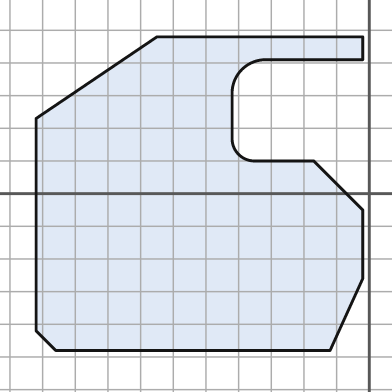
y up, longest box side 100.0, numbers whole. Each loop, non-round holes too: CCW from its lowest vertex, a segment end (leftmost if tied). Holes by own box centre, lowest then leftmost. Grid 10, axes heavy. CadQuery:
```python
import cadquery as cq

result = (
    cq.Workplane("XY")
    .moveTo(-96.0, -48.0)
    .lineTo(-12.0, -48.0)
    .lineTo(-2.0, -26.0)
    .lineTo(-2.0, -5.0)
    .lineTo(-17.0, 10.0)
    .lineTo(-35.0, 10.0)
    .threePointArc((-40.0, 12.0), (-42.0, 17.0))
    .lineTo(-42.0, 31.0)
    .threePointArc((-39.0, 38.0), (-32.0, 41.0))
    .lineTo(-2.0, 41.0)
    .lineTo(-2.0, 48.0)
    .lineTo(-65.0, 48.0)
    .lineTo(-102.0, 23.0)
    .lineTo(-102.0, -42.0)
    .close()
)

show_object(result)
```